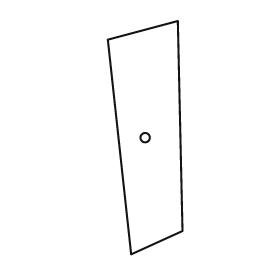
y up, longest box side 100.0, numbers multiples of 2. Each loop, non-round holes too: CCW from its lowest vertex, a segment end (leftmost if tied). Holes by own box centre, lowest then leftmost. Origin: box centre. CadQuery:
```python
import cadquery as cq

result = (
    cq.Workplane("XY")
    .moveTo(-6.0, -50.0)
    .lineTo(16.0, -40.0)
    .lineTo(14.0, 50.0)
    .lineTo(-16.0, 42.0)
    .close()
    .moveTo(0.0, 0.0)
    .circle(2.0)
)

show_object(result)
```